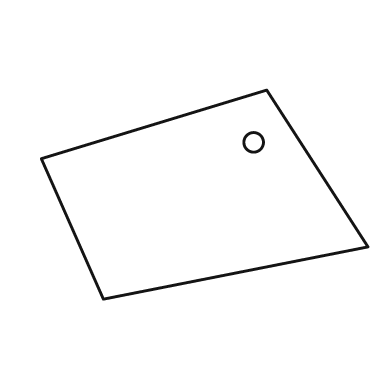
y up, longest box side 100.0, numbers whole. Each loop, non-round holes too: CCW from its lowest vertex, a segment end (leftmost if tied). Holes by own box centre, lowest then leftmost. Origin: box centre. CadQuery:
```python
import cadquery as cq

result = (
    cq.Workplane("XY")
    .moveTo(-31.0, -32.0)
    .lineTo(50.0, -16.0)
    .lineTo(19.0, 32.0)
    .lineTo(-50.0, 11.0)
    .close()
    .moveTo(15.0, 16.0)
    .circle(3.0)
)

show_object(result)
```